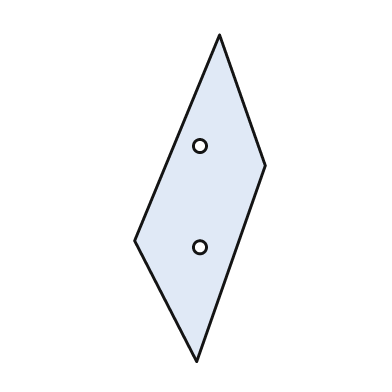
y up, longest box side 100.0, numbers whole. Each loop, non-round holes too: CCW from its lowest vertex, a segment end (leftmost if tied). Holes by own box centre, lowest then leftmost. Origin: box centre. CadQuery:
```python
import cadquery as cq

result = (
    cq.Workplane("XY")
    .moveTo(-1.0, -50.0)
    .lineTo(20.0, 10.0)
    .lineTo(6.0, 50.0)
    .lineTo(-20.0, -13.0)
    .close()
    .moveTo(0.0, -15.0)
    .circle(2.0)
    .moveTo(0.0, 16.0)
    .circle(2.0)
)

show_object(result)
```